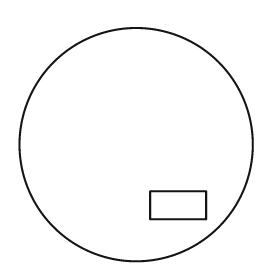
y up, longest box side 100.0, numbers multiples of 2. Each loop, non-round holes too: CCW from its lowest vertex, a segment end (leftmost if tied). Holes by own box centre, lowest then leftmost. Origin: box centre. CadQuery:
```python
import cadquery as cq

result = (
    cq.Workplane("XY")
    .moveTo(0.0, 0.0)
    .circle(50.0)
    .moveTo(6.0, -32.0)
    .lineTo(30.0, -32.0)
    .lineTo(30.0, -20.0)
    .lineTo(6.0, -20.0)
    .close()
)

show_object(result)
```